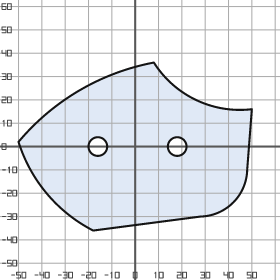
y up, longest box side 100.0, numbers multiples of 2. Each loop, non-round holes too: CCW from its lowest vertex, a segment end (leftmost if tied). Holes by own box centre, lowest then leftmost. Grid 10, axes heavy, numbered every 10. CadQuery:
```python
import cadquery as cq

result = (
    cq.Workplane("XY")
    .moveTo(-18.0, -36.0)
    .lineTo(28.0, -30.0)
    .threePointArc((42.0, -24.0), (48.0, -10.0))
    .lineTo(50.0, 16.0)
    .threePointArc((26.0, 20.0), (8.0, 36.0))
    .threePointArc((-24.0, 24.0), (-50.0, 2.0))
    .threePointArc((-38.0, -20.0), (-18.0, -36.0))
    .close()
    .moveTo(-16.0, 0.0)
    .circle(4.0)
    .moveTo(18.0, 0.0)
    .circle(4.0)
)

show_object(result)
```